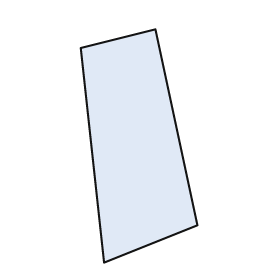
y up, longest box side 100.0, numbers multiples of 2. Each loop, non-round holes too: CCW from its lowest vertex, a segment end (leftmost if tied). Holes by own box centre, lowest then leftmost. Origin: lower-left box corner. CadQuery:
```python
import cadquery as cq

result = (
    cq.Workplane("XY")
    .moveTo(10.0, 0.0)
    .lineTo(50.0, 16.0)
    .lineTo(32.0, 100.0)
    .lineTo(0.0, 92.0)
    .close()
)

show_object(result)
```